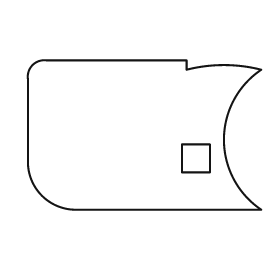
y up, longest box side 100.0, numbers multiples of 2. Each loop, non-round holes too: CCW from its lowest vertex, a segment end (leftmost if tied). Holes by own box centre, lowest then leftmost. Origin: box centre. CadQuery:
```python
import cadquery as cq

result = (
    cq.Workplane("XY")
    .moveTo(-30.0, -32.0)
    .lineTo(50.0, -32.0)
    .threePointArc((34.0, -2.0), (50.0, 28.0))
    .threePointArc((34.0, 30.0), (18.0, 28.0))
    .lineTo(18.0, 32.0)
    .lineTo(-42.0, 32.0)
    .threePointArc((-48.0, 30.0), (-50.0, 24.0))
    .lineTo(-50.0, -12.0)
    .threePointArc((-44.0, -26.0), (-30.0, -32.0))
    .close()
    .moveTo(16.0, -16.0)
    .lineTo(28.0, -16.0)
    .lineTo(28.0, -4.0)
    .lineTo(16.0, -4.0)
    .close()
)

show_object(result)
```